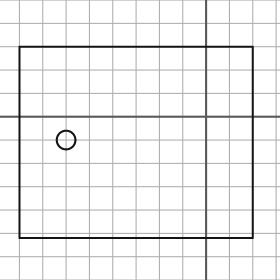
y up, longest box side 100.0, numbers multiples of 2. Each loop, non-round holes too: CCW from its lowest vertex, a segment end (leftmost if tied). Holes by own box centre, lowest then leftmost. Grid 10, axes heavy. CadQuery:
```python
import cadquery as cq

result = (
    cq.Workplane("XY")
    .moveTo(-80.0, -52.0)
    .lineTo(20.0, -52.0)
    .lineTo(20.0, 30.0)
    .lineTo(-80.0, 30.0)
    .close()
    .moveTo(-60.0, -10.0)
    .circle(4.0)
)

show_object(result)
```